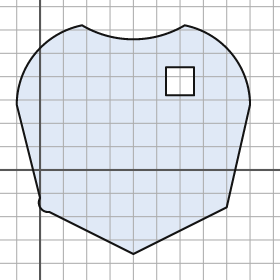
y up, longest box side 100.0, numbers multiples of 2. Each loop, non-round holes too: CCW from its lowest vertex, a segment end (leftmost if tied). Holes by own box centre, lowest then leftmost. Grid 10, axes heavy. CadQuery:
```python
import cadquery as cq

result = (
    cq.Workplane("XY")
    .moveTo(40.0, -36.0)
    .lineTo(80.0, -16.0)
    .lineTo(90.0, 28.0)
    .threePointArc((82.0, 50.0), (62.0, 62.0))
    .threePointArc((40.0, 56.0), (18.0, 62.0))
    .threePointArc((-2.0, 50.0), (-10.0, 28.0))
    .lineTo(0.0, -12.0)
    .threePointArc((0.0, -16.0), (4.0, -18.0))
    .close()
    .moveTo(54.0, 32.0)
    .lineTo(66.0, 32.0)
    .lineTo(66.0, 44.0)
    .lineTo(54.0, 44.0)
    .close()
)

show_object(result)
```